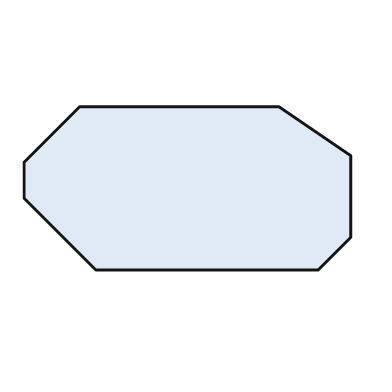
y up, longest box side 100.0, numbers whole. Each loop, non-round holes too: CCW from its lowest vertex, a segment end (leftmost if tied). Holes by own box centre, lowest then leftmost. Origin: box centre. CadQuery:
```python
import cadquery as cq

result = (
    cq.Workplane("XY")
    .moveTo(-28.0, -25.0)
    .lineTo(40.0, -25.0)
    .lineTo(50.0, -15.0)
    .lineTo(50.0, 10.0)
    .lineTo(28.0, 25.0)
    .lineTo(-33.0, 25.0)
    .lineTo(-50.0, 8.0)
    .lineTo(-50.0, -3.0)
    .close()
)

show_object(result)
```